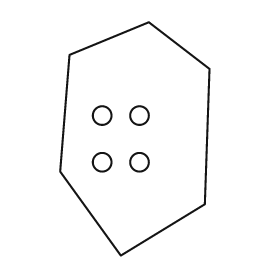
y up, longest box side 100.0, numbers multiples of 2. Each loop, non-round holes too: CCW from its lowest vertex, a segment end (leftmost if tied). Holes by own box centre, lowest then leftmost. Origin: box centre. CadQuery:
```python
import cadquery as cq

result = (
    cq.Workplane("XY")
    .moveTo(-6.0, -50.0)
    .lineTo(30.0, -28.0)
    .lineTo(32.0, 30.0)
    .lineTo(6.0, 50.0)
    .lineTo(-28.0, 36.0)
    .lineTo(-32.0, -14.0)
    .close()
    .moveTo(-14.0, -10.0)
    .circle(4.0)
    .moveTo(2.0, -10.0)
    .circle(4.0)
    .moveTo(-14.0, 10.0)
    .circle(4.0)
    .moveTo(2.0, 10.0)
    .circle(4.0)
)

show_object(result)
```